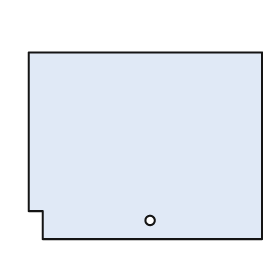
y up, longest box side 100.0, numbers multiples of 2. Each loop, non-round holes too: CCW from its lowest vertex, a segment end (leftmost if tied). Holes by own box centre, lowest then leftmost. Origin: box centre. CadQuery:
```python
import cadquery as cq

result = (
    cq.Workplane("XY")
    .moveTo(-44.0, -40.0)
    .lineTo(50.0, -40.0)
    .lineTo(50.0, 40.0)
    .lineTo(-50.0, 40.0)
    .lineTo(-50.0, -28.0)
    .lineTo(-44.0, -28.0)
    .close()
    .moveTo(2.0, -32.0)
    .circle(2.0)
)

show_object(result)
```